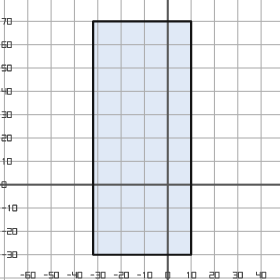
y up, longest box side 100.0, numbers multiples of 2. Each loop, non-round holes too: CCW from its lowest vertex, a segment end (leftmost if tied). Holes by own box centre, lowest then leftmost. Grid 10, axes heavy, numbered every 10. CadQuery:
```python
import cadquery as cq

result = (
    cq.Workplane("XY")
    .moveTo(-32.0, -30.0)
    .lineTo(10.0, -30.0)
    .lineTo(10.0, 70.0)
    .lineTo(-32.0, 70.0)
    .close()
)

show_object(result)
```